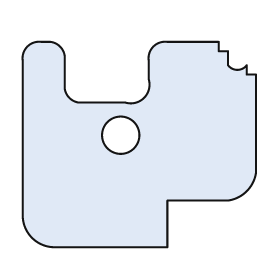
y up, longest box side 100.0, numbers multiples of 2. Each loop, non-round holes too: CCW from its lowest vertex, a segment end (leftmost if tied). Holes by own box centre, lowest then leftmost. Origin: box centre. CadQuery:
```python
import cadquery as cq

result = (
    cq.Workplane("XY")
    .moveTo(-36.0, -44.0)
    .lineTo(12.0, -44.0)
    .lineTo(12.0, -24.0)
    .lineTo(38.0, -24.0)
    .threePointArc((46.0, -20.0), (50.0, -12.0))
    .lineTo(50.0, 30.0)
    .lineTo(46.0, 30.0)
    .lineTo(46.0, 34.0)
    .threePointArc((42.0, 32.0), (38.0, 34.0))
    .lineTo(38.0, 40.0)
    .lineTo(34.0, 40.0)
    .lineTo(34.0, 44.0)
    .lineTo(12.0, 44.0)
    .threePointArc((6.0, 42.0), (4.0, 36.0))
    .lineTo(4.0, 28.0)
    .threePointArc((2.0, 20.0), (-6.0, 18.0))
    .lineTo(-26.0, 18.0)
    .threePointArc((-30.0, 20.0), (-32.0, 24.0))
    .lineTo(-32.0, 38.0)
    .threePointArc((-34.0, 42.0), (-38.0, 44.0))
    .lineTo(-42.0, 44.0)
    .threePointArc((-48.0, 42.0), (-50.0, 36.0))
    .lineTo(-50.0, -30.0)
    .threePointArc((-46.0, -40.0), (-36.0, -44.0))
    .close()
    .moveTo(-8.0, 4.0)
    .circle(8.0)
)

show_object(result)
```